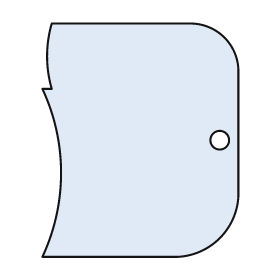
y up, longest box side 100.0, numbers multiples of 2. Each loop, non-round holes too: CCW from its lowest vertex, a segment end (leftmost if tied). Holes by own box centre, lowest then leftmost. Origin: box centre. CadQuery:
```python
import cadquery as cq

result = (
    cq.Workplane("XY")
    .moveTo(-42.0, -50.0)
    .lineTo(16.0, -50.0)
    .threePointArc((34.0, -42.0), (42.0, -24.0))
    .lineTo(42.0, 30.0)
    .threePointArc((36.0, 44.0), (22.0, 50.0))
    .lineTo(-38.0, 50.0)
    .threePointArc((-40.0, 36.0), (-38.0, 22.0))
    .lineTo(-42.0, 22.0)
    .threePointArc((-34.0, -14.0), (-42.0, -50.0))
    .close()
    .moveTo(34.0, 0.0)
    .circle(4.0)
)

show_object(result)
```